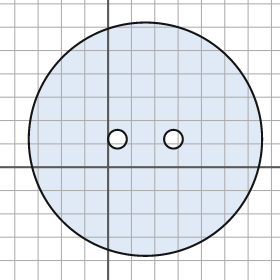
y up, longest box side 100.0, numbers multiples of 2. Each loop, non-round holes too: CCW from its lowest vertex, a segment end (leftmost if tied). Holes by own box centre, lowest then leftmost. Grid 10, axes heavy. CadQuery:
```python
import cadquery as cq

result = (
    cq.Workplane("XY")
    .moveTo(16.0, 12.0)
    .circle(50.0)
    .moveTo(4.0, 12.0)
    .circle(4.0)
    .moveTo(28.0, 12.0)
    .circle(4.0)
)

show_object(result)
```